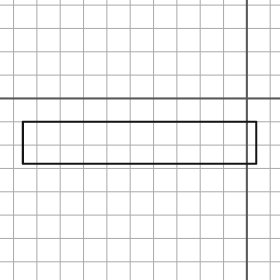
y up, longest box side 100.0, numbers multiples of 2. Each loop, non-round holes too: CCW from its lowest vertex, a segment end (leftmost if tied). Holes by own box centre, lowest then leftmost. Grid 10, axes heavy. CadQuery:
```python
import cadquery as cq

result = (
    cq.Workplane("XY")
    .moveTo(-96.0, -28.0)
    .lineTo(4.0, -28.0)
    .lineTo(4.0, -10.0)
    .lineTo(-96.0, -10.0)
    .close()
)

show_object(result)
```